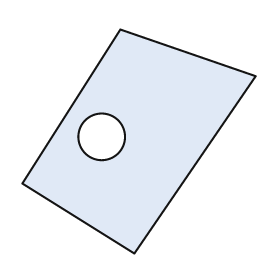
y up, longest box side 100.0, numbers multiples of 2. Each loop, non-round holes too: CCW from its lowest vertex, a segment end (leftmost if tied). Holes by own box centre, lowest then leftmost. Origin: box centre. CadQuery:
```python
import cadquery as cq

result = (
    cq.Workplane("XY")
    .moveTo(-2.0, -48.0)
    .lineTo(50.0, 28.0)
    .lineTo(-8.0, 48.0)
    .lineTo(-50.0, -18.0)
    .close()
    .moveTo(-16.0, 2.0)
    .circle(10.0)
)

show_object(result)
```